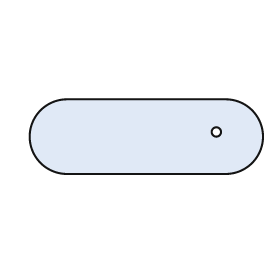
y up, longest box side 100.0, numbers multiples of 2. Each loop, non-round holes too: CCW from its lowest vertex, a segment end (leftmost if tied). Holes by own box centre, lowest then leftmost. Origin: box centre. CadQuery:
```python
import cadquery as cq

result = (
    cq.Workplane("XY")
    .moveTo(-34.0, -16.0)
    .lineTo(34.0, -16.0)
    .threePointArc((50.0, 0.0), (34.0, 16.0))
    .lineTo(-34.0, 16.0)
    .threePointArc((-50.0, 0.0), (-34.0, -16.0))
    .close()
    .moveTo(30.0, 2.0)
    .circle(2.0)
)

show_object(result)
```